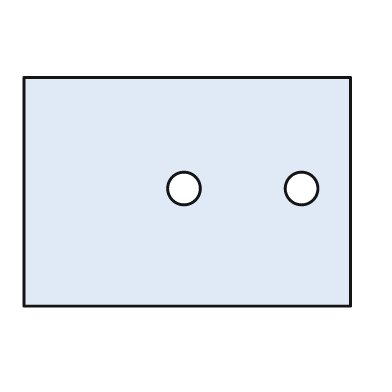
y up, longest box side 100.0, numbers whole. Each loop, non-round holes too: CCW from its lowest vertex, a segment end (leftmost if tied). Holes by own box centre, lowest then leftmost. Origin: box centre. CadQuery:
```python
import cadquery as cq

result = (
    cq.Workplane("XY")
    .moveTo(-50.0, -35.0)
    .lineTo(50.0, -35.0)
    .lineTo(50.0, 35.0)
    .lineTo(-50.0, 35.0)
    .close()
    .moveTo(-1.0, 1.0)
    .circle(5.0)
    .moveTo(35.0, 1.0)
    .circle(5.0)
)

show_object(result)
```